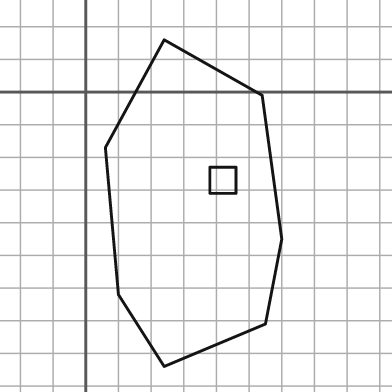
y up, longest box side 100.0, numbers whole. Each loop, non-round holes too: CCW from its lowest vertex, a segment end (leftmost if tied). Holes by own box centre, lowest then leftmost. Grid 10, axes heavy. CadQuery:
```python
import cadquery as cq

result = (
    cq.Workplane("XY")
    .moveTo(24.0, -84.0)
    .lineTo(55.0, -71.0)
    .lineTo(60.0, -45.0)
    .lineTo(54.0, -1.0)
    .lineTo(24.0, 16.0)
    .lineTo(6.0, -17.0)
    .lineTo(10.0, -62.0)
    .close()
    .moveTo(38.0, -31.0)
    .lineTo(46.0, -31.0)
    .lineTo(46.0, -23.0)
    .lineTo(38.0, -23.0)
    .close()
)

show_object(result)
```